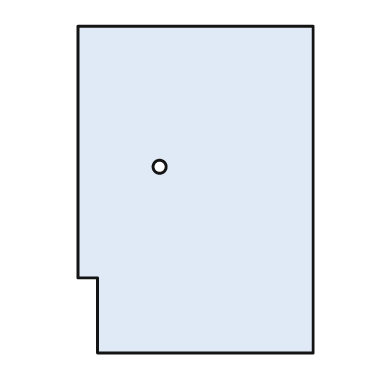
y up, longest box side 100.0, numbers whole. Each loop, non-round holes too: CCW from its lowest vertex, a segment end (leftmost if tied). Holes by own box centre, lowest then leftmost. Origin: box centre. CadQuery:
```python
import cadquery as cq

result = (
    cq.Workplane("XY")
    .moveTo(-30.0, -50.0)
    .lineTo(36.0, -50.0)
    .lineTo(36.0, 50.0)
    .lineTo(-36.0, 50.0)
    .lineTo(-36.0, -27.0)
    .lineTo(-30.0, -27.0)
    .close()
    .moveTo(-11.0, 7.0)
    .circle(2.0)
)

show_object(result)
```